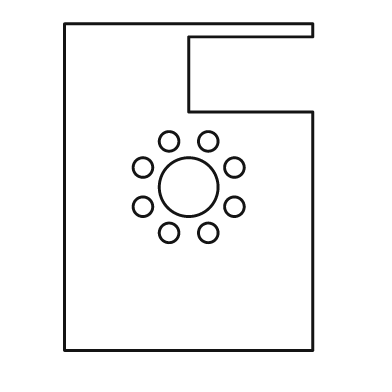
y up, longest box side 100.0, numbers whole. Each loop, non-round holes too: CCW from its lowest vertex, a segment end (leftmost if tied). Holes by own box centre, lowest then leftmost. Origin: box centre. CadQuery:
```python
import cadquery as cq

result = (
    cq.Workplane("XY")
    .moveTo(-38.0, -50.0)
    .lineTo(38.0, -50.0)
    .lineTo(38.0, 23.0)
    .lineTo(0.0, 23.0)
    .lineTo(0.0, 46.0)
    .lineTo(38.0, 46.0)
    .lineTo(38.0, 50.0)
    .lineTo(-38.0, 50.0)
    .close()
    .moveTo(-6.0, -14.0)
    .circle(3.0)
    .moveTo(6.0, -14.0)
    .circle(3.0)
    .moveTo(-14.0, -6.0)
    .circle(3.0)
    .moveTo(14.0, -6.0)
    .circle(3.0)
    .moveTo(0.0, 0.0)
    .circle(9.0)
    .moveTo(-14.0, 6.0)
    .circle(3.0)
    .moveTo(14.0, 6.0)
    .circle(3.0)
    .moveTo(-6.0, 14.0)
    .circle(3.0)
    .moveTo(6.0, 14.0)
    .circle(3.0)
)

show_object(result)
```